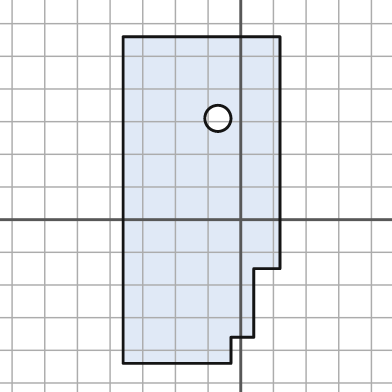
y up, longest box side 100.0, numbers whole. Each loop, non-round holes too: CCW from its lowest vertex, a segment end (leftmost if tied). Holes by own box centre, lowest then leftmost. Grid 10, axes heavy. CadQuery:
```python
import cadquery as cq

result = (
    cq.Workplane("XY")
    .moveTo(-36.0, -44.0)
    .lineTo(-3.0, -44.0)
    .lineTo(-3.0, -36.0)
    .lineTo(4.0, -36.0)
    .lineTo(4.0, -15.0)
    .lineTo(12.0, -15.0)
    .lineTo(12.0, 56.0)
    .lineTo(-36.0, 56.0)
    .close()
    .moveTo(-7.0, 31.0)
    .circle(4.0)
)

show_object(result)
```